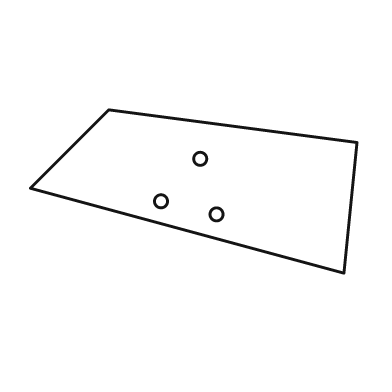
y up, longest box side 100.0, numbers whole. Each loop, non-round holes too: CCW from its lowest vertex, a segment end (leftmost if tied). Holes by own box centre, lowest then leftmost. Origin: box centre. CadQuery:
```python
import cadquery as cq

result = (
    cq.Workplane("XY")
    .moveTo(46.0, -25.0)
    .lineTo(50.0, 15.0)
    .lineTo(-26.0, 25.0)
    .lineTo(-50.0, 1.0)
    .close()
    .moveTo(7.0, -7.0)
    .circle(2.0)
    .moveTo(-10.0, -3.0)
    .circle(2.0)
    .moveTo(2.0, 10.0)
    .circle(2.0)
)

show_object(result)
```